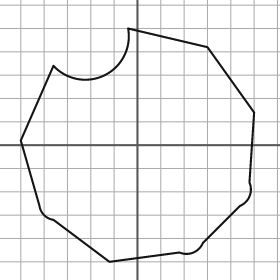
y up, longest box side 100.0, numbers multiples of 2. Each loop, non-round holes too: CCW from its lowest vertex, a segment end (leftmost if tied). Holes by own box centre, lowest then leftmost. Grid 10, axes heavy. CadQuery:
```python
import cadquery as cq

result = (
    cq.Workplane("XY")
    .moveTo(-12.0, -50.0)
    .lineTo(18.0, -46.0)
    .threePointArc((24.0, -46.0), (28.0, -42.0))
    .lineTo(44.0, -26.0)
    .threePointArc((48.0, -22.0), (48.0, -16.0))
    .lineTo(50.0, 14.0)
    .lineTo(30.0, 42.0)
    .lineTo(-4.0, 50.0)
    .threePointArc((-14.0, 30.0), (-36.0, 34.0))
    .lineTo(-50.0, 2.0)
    .lineTo(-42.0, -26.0)
    .threePointArc((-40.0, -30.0), (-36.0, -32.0))
    .close()
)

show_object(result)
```